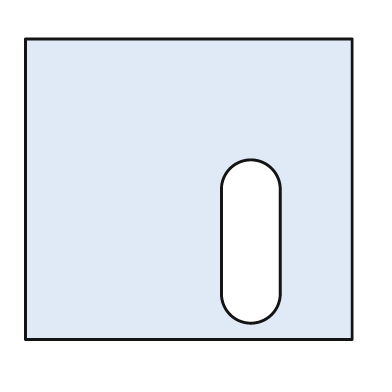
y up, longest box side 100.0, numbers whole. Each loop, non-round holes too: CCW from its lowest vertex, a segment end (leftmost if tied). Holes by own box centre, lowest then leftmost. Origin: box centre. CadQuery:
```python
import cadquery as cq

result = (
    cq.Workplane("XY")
    .moveTo(-50.0, -46.0)
    .lineTo(50.0, -46.0)
    .lineTo(50.0, 46.0)
    .lineTo(-50.0, 46.0)
    .close()
    .moveTo(10.0, -32.0)
    .threePointArc((19.0, -41.0), (28.0, -32.0))
    .lineTo(28.0, 0.0)
    .threePointArc((19.0, 9.0), (10.0, 0.0))
    .close()
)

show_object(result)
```